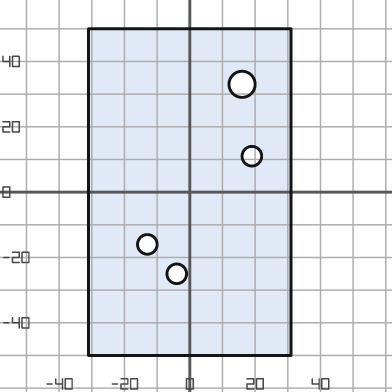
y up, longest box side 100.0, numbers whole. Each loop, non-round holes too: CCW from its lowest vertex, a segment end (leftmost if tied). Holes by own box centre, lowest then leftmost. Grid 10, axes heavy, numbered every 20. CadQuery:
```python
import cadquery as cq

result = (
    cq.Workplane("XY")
    .moveTo(-31.0, -50.0)
    .lineTo(31.0, -50.0)
    .lineTo(31.0, 50.0)
    .lineTo(-31.0, 50.0)
    .close()
    .moveTo(-4.0, -25.0)
    .circle(3.0)
    .moveTo(-13.0, -16.0)
    .circle(3.0)
    .moveTo(19.0, 11.0)
    .circle(3.0)
    .moveTo(16.0, 33.0)
    .circle(4.0)
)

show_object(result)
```